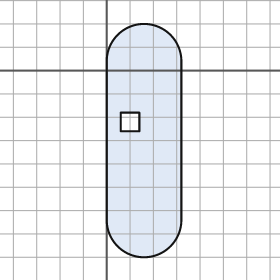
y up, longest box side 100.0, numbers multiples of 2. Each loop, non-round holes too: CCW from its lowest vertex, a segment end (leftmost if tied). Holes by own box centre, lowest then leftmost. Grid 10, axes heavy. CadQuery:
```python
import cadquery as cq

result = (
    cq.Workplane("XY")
    .moveTo(0.0, -64.0)
    .threePointArc((16.0, -80.0), (32.0, -64.0))
    .lineTo(32.0, 4.0)
    .threePointArc((16.0, 20.0), (0.0, 4.0))
    .close()
    .moveTo(6.0, -26.0)
    .lineTo(14.0, -26.0)
    .lineTo(14.0, -18.0)
    .lineTo(6.0, -18.0)
    .close()
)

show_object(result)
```